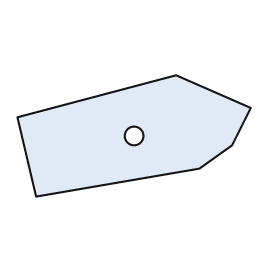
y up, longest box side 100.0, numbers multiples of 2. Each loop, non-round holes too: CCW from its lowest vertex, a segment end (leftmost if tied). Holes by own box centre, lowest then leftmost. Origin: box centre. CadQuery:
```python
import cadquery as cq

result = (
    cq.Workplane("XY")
    .moveTo(-42.0, -26.0)
    .lineTo(28.0, -14.0)
    .lineTo(42.0, -4.0)
    .lineTo(50.0, 12.0)
    .lineTo(18.0, 26.0)
    .lineTo(-50.0, 8.0)
    .close()
    .moveTo(0.0, 0.0)
    .circle(4.0)
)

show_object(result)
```